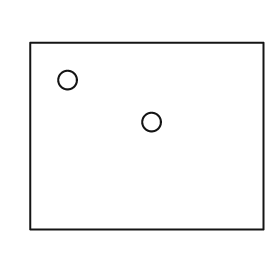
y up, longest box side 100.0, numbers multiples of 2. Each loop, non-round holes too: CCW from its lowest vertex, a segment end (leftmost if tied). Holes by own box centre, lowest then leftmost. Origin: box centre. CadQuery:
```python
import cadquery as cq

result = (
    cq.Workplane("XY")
    .moveTo(-50.0, -40.0)
    .lineTo(50.0, -40.0)
    .lineTo(50.0, 40.0)
    .lineTo(-50.0, 40.0)
    .close()
    .moveTo(2.0, 6.0)
    .circle(4.0)
    .moveTo(-34.0, 24.0)
    .circle(4.0)
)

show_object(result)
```